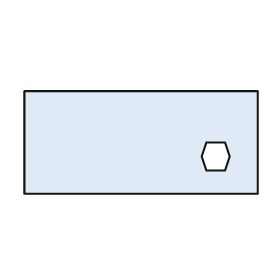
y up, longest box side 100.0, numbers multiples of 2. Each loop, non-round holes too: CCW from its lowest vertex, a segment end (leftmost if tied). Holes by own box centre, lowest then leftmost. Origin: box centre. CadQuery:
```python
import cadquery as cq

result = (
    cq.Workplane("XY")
    .moveTo(-50.0, -22.0)
    .lineTo(50.0, -22.0)
    .lineTo(50.0, 22.0)
    .lineTo(-50.0, 22.0)
    .close()
    .moveTo(28.0, -12.0)
    .lineTo(36.0, -12.0)
    .lineTo(38.0, -6.0)
    .lineTo(36.0, 0.0)
    .lineTo(28.0, 0.0)
    .lineTo(26.0, -6.0)
    .close()
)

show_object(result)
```